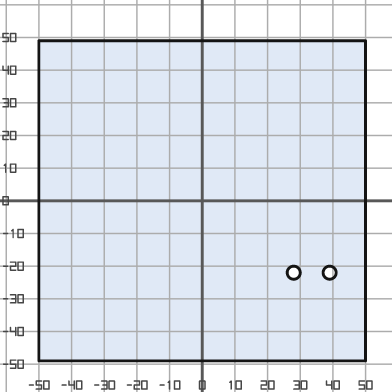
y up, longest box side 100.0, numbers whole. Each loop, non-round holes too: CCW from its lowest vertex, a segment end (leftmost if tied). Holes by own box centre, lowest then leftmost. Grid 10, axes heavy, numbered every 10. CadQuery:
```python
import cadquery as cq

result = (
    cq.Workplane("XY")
    .moveTo(-50.0, -49.0)
    .lineTo(50.0, -49.0)
    .lineTo(50.0, 49.0)
    .lineTo(-50.0, 49.0)
    .close()
    .moveTo(28.0, -22.0)
    .circle(2.0)
    .moveTo(39.0, -22.0)
    .circle(2.0)
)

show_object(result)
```